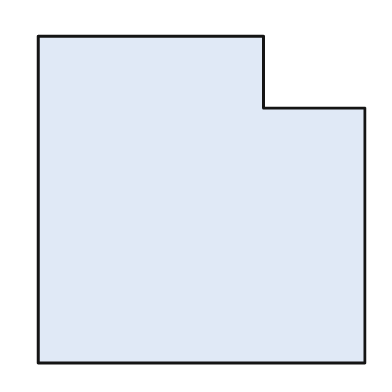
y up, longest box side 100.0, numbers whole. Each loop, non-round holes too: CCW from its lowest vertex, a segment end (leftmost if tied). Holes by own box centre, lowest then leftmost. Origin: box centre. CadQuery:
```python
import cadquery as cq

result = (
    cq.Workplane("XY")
    .moveTo(-50.0, -50.0)
    .lineTo(50.0, -50.0)
    .lineTo(50.0, 28.0)
    .lineTo(19.0, 28.0)
    .lineTo(19.0, 50.0)
    .lineTo(-50.0, 50.0)
    .close()
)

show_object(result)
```